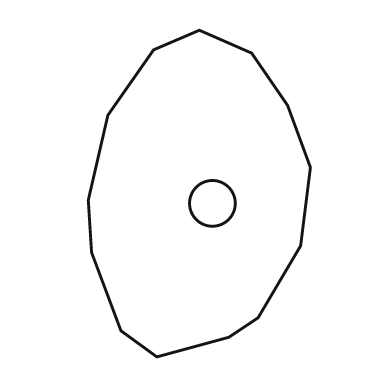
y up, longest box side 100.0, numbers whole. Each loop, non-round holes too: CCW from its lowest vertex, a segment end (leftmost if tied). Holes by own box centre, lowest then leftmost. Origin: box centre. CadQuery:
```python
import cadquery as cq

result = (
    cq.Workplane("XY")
    .moveTo(-13.0, -50.0)
    .lineTo(9.0, -44.0)
    .lineTo(18.0, -38.0)
    .lineTo(31.0, -16.0)
    .lineTo(34.0, 8.0)
    .lineTo(27.0, 27.0)
    .lineTo(16.0, 43.0)
    .lineTo(0.0, 50.0)
    .lineTo(-14.0, 44.0)
    .lineTo(-28.0, 24.0)
    .lineTo(-34.0, -2.0)
    .lineTo(-33.0, -18.0)
    .lineTo(-24.0, -42.0)
    .close()
    .moveTo(4.0, -3.0)
    .circle(7.0)
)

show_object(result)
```